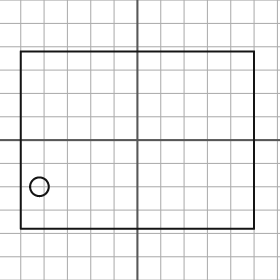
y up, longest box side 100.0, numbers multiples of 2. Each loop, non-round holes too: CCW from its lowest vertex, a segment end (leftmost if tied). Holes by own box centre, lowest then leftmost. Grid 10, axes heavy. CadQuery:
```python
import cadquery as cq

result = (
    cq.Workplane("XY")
    .moveTo(-50.0, -38.0)
    .lineTo(50.0, -38.0)
    .lineTo(50.0, 38.0)
    .lineTo(-50.0, 38.0)
    .close()
    .moveTo(-42.0, -20.0)
    .circle(4.0)
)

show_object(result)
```